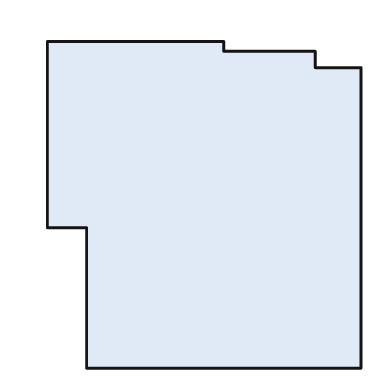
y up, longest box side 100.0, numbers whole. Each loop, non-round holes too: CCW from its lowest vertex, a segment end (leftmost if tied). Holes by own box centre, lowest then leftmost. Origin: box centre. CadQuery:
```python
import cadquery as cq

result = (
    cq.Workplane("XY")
    .moveTo(-36.0, -50.0)
    .lineTo(48.0, -50.0)
    .lineTo(48.0, 42.0)
    .lineTo(34.0, 42.0)
    .lineTo(34.0, 47.0)
    .lineTo(6.0, 47.0)
    .lineTo(6.0, 50.0)
    .lineTo(-48.0, 50.0)
    .lineTo(-48.0, -7.0)
    .lineTo(-36.0, -7.0)
    .close()
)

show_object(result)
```